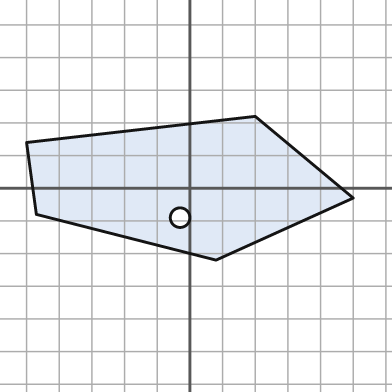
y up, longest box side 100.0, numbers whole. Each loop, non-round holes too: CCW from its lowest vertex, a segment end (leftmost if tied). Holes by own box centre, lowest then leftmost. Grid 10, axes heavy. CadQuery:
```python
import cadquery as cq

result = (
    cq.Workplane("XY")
    .moveTo(8.0, -22.0)
    .lineTo(50.0, -3.0)
    .lineTo(20.0, 22.0)
    .lineTo(-50.0, 14.0)
    .lineTo(-47.0, -8.0)
    .close()
    .moveTo(-3.0, -9.0)
    .circle(3.0)
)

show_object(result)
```